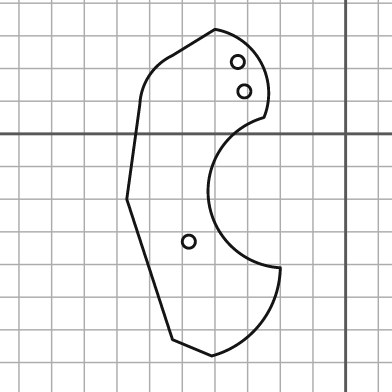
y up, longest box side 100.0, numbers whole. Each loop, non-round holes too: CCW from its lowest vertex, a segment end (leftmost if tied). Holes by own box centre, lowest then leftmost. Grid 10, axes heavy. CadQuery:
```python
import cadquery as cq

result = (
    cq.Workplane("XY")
    .moveTo(-41.0, -68.0)
    .threePointArc((-26.0, -58.0), (-20.0, -41.0))
    .threePointArc((-42.0, -20.0), (-25.0, 5.0))
    .threePointArc((-26.0, 22.0), (-40.0, 32.0))
    .lineTo(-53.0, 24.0)
    .threePointArc((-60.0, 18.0), (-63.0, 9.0))
    .lineTo(-67.0, -20.0)
    .lineTo(-53.0, -63.0)
    .close()
    .moveTo(-48.0, -33.0)
    .circle(2.0)
    .moveTo(-31.0, 13.0)
    .circle(2.0)
    .moveTo(-33.0, 22.0)
    .circle(2.0)
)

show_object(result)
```